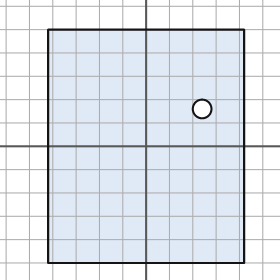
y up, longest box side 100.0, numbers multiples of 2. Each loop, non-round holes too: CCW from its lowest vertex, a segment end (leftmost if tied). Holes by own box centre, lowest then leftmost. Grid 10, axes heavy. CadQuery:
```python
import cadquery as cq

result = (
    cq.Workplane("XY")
    .moveTo(-42.0, -50.0)
    .lineTo(42.0, -50.0)
    .lineTo(42.0, 50.0)
    .lineTo(-42.0, 50.0)
    .close()
    .moveTo(24.0, 16.0)
    .circle(4.0)
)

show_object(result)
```